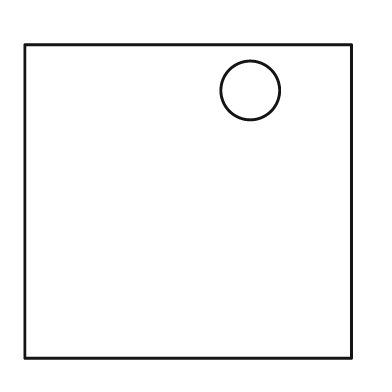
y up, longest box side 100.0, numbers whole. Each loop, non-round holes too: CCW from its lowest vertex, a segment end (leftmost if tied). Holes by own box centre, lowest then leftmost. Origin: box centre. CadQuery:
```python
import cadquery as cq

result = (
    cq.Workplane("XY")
    .moveTo(-50.0, -48.0)
    .lineTo(50.0, -48.0)
    .lineTo(50.0, 48.0)
    .lineTo(-50.0, 48.0)
    .close()
    .moveTo(19.0, 34.0)
    .circle(9.0)
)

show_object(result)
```